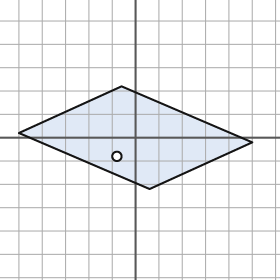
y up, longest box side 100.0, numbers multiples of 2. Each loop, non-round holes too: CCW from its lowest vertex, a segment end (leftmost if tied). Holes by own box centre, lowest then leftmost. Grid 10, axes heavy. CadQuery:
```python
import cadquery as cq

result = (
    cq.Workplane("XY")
    .moveTo(6.0, -22.0)
    .lineTo(50.0, -2.0)
    .lineTo(-6.0, 22.0)
    .lineTo(-50.0, 2.0)
    .close()
    .moveTo(-8.0, -8.0)
    .circle(2.0)
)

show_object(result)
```